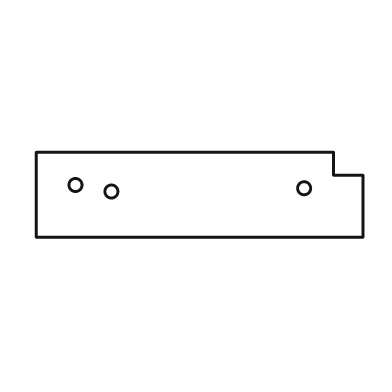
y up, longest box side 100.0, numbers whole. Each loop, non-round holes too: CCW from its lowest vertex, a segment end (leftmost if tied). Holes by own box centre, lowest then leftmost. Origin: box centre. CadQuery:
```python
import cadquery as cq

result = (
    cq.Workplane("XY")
    .moveTo(-50.0, -13.0)
    .lineTo(50.0, -13.0)
    .lineTo(50.0, 6.0)
    .lineTo(41.0, 6.0)
    .lineTo(41.0, 13.0)
    .lineTo(-50.0, 13.0)
    .close()
    .moveTo(-27.0, 1.0)
    .circle(2.0)
    .moveTo(32.0, 2.0)
    .circle(2.0)
    .moveTo(-38.0, 3.0)
    .circle(2.0)
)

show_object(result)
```